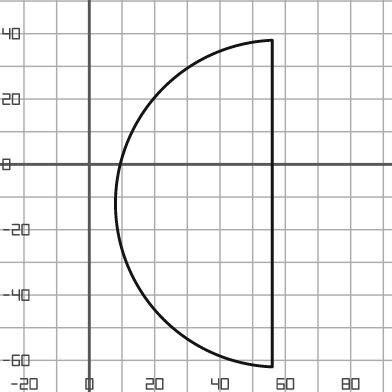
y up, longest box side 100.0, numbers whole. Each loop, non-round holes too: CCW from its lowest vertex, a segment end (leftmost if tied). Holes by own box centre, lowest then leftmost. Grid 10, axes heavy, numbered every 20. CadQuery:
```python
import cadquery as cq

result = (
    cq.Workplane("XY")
    .moveTo(56.0, -62.0)
    .lineTo(56.0, 38.0)
    .threePointArc((8.0, -12.0), (56.0, -62.0))
    .close()
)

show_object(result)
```